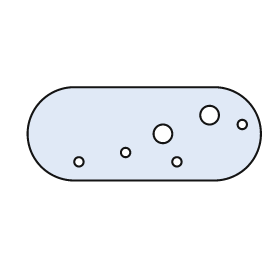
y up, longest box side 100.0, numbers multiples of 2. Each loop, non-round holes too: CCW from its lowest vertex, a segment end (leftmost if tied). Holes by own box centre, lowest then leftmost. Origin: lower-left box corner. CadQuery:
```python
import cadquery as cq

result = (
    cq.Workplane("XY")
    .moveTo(20.0, 0.0)
    .lineTo(80.0, 0.0)
    .threePointArc((100.0, 20.0), (80.0, 40.0))
    .lineTo(20.0, 40.0)
    .threePointArc((0.0, 20.0), (20.0, 0.0))
    .close()
    .moveTo(22.0, 8.0)
    .circle(2.0)
    .moveTo(64.0, 8.0)
    .circle(2.0)
    .moveTo(42.0, 12.0)
    .circle(2.0)
    .moveTo(58.0, 20.0)
    .circle(4.0)
    .moveTo(92.0, 24.0)
    .circle(2.0)
    .moveTo(78.0, 28.0)
    .circle(4.0)
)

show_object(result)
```